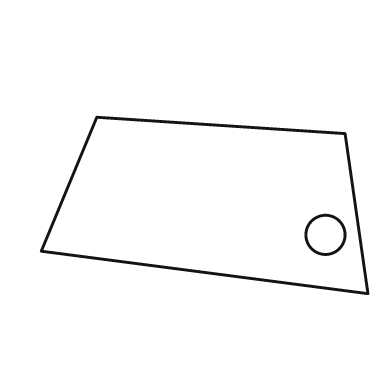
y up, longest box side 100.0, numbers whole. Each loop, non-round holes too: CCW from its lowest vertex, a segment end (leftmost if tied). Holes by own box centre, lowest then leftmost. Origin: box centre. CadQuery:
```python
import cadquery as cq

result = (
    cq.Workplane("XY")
    .moveTo(50.0, -27.0)
    .lineTo(43.0, 22.0)
    .lineTo(-33.0, 27.0)
    .lineTo(-50.0, -14.0)
    .close()
    .moveTo(37.0, -9.0)
    .circle(6.0)
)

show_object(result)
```